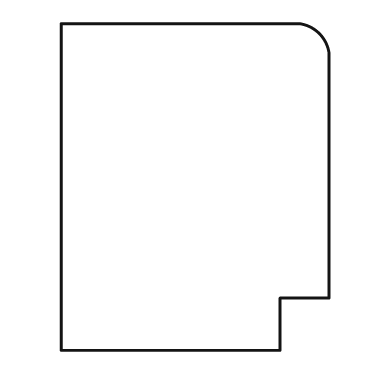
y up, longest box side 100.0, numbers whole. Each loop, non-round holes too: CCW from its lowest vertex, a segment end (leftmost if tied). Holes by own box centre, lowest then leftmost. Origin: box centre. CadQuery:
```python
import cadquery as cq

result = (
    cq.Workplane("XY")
    .moveTo(-41.0, -50.0)
    .lineTo(26.0, -50.0)
    .lineTo(26.0, -34.0)
    .lineTo(41.0, -34.0)
    .lineTo(41.0, 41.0)
    .threePointArc((38.0, 47.0), (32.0, 50.0))
    .lineTo(-41.0, 50.0)
    .close()
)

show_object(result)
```